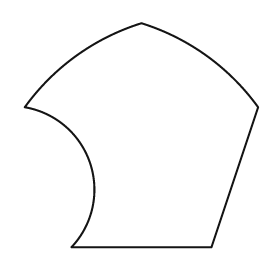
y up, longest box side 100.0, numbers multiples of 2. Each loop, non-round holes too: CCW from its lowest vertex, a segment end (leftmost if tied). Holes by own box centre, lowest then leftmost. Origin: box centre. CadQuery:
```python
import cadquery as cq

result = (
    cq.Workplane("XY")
    .moveTo(-30.0, -48.0)
    .lineTo(30.0, -48.0)
    .lineTo(50.0, 12.0)
    .threePointArc((28.0, 34.0), (0.0, 48.0))
    .threePointArc((-28.0, 34.0), (-50.0, 12.0))
    .threePointArc((-22.0, -12.0), (-30.0, -48.0))
    .close()
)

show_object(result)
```